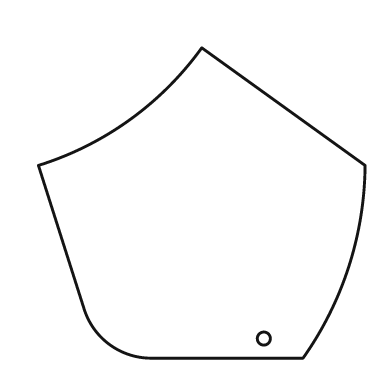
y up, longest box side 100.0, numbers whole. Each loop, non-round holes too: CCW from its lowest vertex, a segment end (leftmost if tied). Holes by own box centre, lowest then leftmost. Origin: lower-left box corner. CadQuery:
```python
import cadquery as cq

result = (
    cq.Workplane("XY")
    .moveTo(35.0, 0.0)
    .lineTo(81.0, 0.0)
    .threePointArc((95.0, 28.0), (100.0, 59.0))
    .lineTo(50.0, 95.0)
    .threePointArc((28.0, 73.0), (0.0, 59.0))
    .lineTo(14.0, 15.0)
    .threePointArc((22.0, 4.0), (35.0, 0.0))
    .close()
    .moveTo(69.0, 6.0)
    .circle(2.0)
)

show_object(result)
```